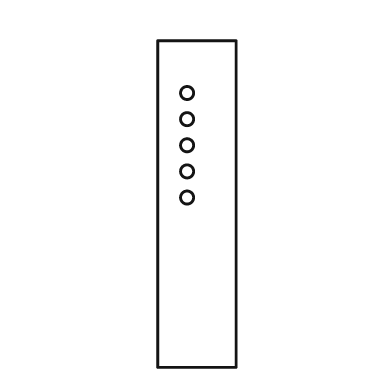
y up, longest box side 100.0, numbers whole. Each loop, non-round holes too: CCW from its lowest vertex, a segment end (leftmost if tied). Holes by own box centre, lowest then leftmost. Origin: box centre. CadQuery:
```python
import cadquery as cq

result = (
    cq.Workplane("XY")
    .moveTo(-12.0, -50.0)
    .lineTo(12.0, -50.0)
    .lineTo(12.0, 50.0)
    .lineTo(-12.0, 50.0)
    .close()
    .moveTo(-3.0, 2.0)
    .circle(2.0)
    .moveTo(-3.0, 10.0)
    .circle(2.0)
    .moveTo(-3.0, 18.0)
    .circle(2.0)
    .moveTo(-3.0, 26.0)
    .circle(2.0)
    .moveTo(-3.0, 34.0)
    .circle(2.0)
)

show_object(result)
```